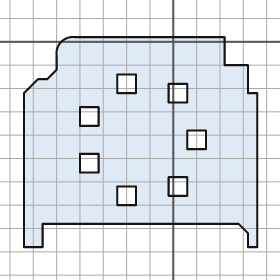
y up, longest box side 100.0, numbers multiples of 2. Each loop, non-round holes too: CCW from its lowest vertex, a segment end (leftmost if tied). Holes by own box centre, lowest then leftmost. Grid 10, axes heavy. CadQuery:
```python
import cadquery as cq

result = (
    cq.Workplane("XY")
    .moveTo(-64.0, -88.0)
    .lineTo(-56.0, -88.0)
    .lineTo(-56.0, -78.0)
    .lineTo(28.0, -78.0)
    .lineTo(32.0, -82.0)
    .lineTo(32.0, -88.0)
    .lineTo(36.0, -88.0)
    .lineTo(36.0, -22.0)
    .lineTo(32.0, -22.0)
    .lineTo(32.0, -10.0)
    .lineTo(22.0, -10.0)
    .lineTo(22.0, 2.0)
    .lineTo(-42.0, 2.0)
    .threePointArc((-48.0, 0.0), (-50.0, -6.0))
    .lineTo(-50.0, -12.0)
    .lineTo(-54.0, -16.0)
    .lineTo(-58.0, -16.0)
    .lineTo(-64.0, -22.0)
    .close()
    .moveTo(-24.0, -70.0)
    .lineTo(-16.0, -70.0)
    .lineTo(-16.0, -62.0)
    .lineTo(-24.0, -62.0)
    .close()
    .moveTo(-2.0, -66.0)
    .lineTo(6.0, -66.0)
    .lineTo(6.0, -58.0)
    .lineTo(-2.0, -58.0)
    .close()
    .moveTo(-40.0, -56.0)
    .lineTo(-32.0, -56.0)
    .lineTo(-32.0, -48.0)
    .lineTo(-40.0, -48.0)
    .close()
    .moveTo(6.0, -46.0)
    .lineTo(14.0, -46.0)
    .lineTo(14.0, -38.0)
    .lineTo(6.0, -38.0)
    .close()
    .moveTo(-40.0, -36.0)
    .lineTo(-32.0, -36.0)
    .lineTo(-32.0, -28.0)
    .lineTo(-40.0, -28.0)
    .close()
    .moveTo(-2.0, -26.0)
    .lineTo(6.0, -26.0)
    .lineTo(6.0, -18.0)
    .lineTo(-2.0, -18.0)
    .close()
    .moveTo(-24.0, -22.0)
    .lineTo(-16.0, -22.0)
    .lineTo(-16.0, -14.0)
    .lineTo(-24.0, -14.0)
    .close()
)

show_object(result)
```